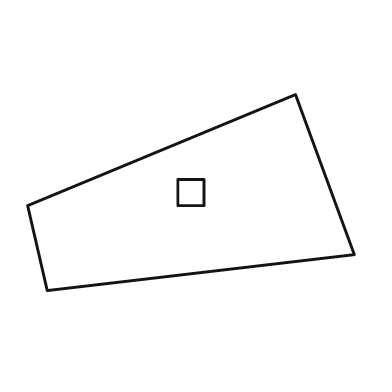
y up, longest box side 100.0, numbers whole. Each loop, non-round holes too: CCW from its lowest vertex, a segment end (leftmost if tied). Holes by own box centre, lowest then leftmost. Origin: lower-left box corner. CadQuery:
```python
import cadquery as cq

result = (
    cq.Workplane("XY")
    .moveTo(6.0, 0.0)
    .lineTo(100.0, 11.0)
    .lineTo(82.0, 60.0)
    .lineTo(0.0, 26.0)
    .close()
    .moveTo(46.0, 26.0)
    .lineTo(54.0, 26.0)
    .lineTo(54.0, 34.0)
    .lineTo(46.0, 34.0)
    .close()
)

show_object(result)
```